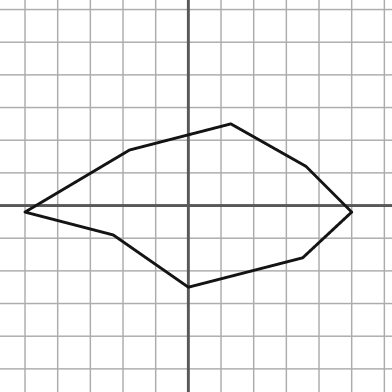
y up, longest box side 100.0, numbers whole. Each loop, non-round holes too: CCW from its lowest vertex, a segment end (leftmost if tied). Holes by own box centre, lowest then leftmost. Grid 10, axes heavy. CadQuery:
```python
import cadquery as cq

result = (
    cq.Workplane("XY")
    .moveTo(0.0, -25.0)
    .lineTo(35.0, -16.0)
    .lineTo(50.0, -2.0)
    .lineTo(36.0, 12.0)
    .lineTo(13.0, 25.0)
    .lineTo(-18.0, 17.0)
    .lineTo(-50.0, -2.0)
    .lineTo(-23.0, -9.0)
    .close()
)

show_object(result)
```